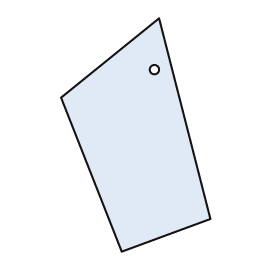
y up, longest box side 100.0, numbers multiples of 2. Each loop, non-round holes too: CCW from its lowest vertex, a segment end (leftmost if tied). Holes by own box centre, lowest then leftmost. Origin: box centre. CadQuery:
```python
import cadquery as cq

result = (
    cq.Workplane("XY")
    .moveTo(-6.0, -50.0)
    .lineTo(32.0, -36.0)
    .lineTo(10.0, 50.0)
    .lineTo(-32.0, 16.0)
    .close()
    .moveTo(8.0, 28.0)
    .circle(2.0)
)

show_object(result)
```